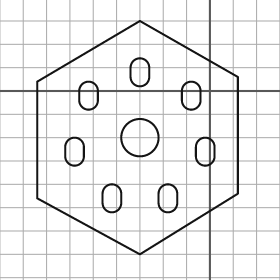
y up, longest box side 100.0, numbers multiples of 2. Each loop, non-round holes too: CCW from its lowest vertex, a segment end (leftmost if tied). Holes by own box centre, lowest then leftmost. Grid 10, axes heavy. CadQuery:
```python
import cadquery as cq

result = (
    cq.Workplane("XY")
    .moveTo(-30.0, -70.0)
    .lineTo(12.0, -44.0)
    .lineTo(12.0, 6.0)
    .lineTo(-30.0, 30.0)
    .lineTo(-74.0, 4.0)
    .lineTo(-74.0, -46.0)
    .close()
    .moveTo(-46.0, -48.0)
    .threePointArc((-42.0, -52.0), (-38.0, -48.0))
    .lineTo(-38.0, -44.0)
    .threePointArc((-42.0, -40.0), (-46.0, -44.0))
    .close()
    .moveTo(-22.0, -48.0)
    .threePointArc((-18.0, -52.0), (-14.0, -48.0))
    .lineTo(-14.0, -44.0)
    .threePointArc((-18.0, -40.0), (-22.0, -44.0))
    .close()
    .moveTo(-62.0, -28.0)
    .threePointArc((-58.0, -32.0), (-54.0, -28.0))
    .lineTo(-54.0, -24.0)
    .threePointArc((-58.0, -20.0), (-62.0, -24.0))
    .close()
    .moveTo(-6.0, -28.0)
    .threePointArc((-2.0, -32.0), (2.0, -28.0))
    .lineTo(2.0, -24.0)
    .threePointArc((-2.0, -20.0), (-6.0, -24.0))
    .close()
    .moveTo(-30.0, -20.0)
    .circle(8.0)
    .moveTo(-56.0, -4.0)
    .threePointArc((-52.0, -8.0), (-48.0, -4.0))
    .lineTo(-48.0, 0.0)
    .threePointArc((-52.0, 4.0), (-56.0, 0.0))
    .close()
    .moveTo(-12.0, -4.0)
    .threePointArc((-8.0, -8.0), (-4.0, -4.0))
    .lineTo(-4.0, 0.0)
    .threePointArc((-8.0, 4.0), (-12.0, 0.0))
    .close()
    .moveTo(-34.0, 6.0)
    .threePointArc((-30.0, 2.0), (-26.0, 6.0))
    .lineTo(-26.0, 10.0)
    .threePointArc((-30.0, 14.0), (-34.0, 10.0))
    .close()
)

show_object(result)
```